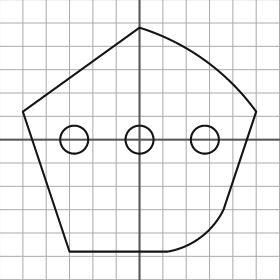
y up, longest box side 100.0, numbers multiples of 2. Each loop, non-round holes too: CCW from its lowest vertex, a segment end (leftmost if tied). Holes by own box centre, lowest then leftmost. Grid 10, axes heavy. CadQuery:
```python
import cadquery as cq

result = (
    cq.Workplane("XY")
    .moveTo(-30.0, -48.0)
    .lineTo(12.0, -48.0)
    .threePointArc((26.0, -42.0), (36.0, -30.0))
    .lineTo(50.0, 12.0)
    .threePointArc((28.0, 34.0), (0.0, 48.0))
    .lineTo(-50.0, 12.0)
    .close()
    .moveTo(-28.0, 0.0)
    .circle(6.0)
    .moveTo(0.0, 0.0)
    .circle(6.0)
    .moveTo(28.0, 0.0)
    .circle(6.0)
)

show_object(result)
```